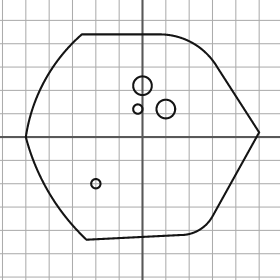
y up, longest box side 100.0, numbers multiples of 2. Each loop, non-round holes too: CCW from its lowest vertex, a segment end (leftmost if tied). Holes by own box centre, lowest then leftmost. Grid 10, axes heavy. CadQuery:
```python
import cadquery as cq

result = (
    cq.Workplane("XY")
    .moveTo(-24.0, -44.0)
    .lineTo(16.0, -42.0)
    .threePointArc((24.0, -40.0), (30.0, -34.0))
    .lineTo(50.0, 2.0)
    .lineTo(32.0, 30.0)
    .threePointArc((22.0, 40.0), (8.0, 44.0))
    .lineTo(-26.0, 44.0)
    .threePointArc((-42.0, 24.0), (-50.0, 0.0))
    .threePointArc((-40.0, -24.0), (-24.0, -44.0))
    .close()
    .moveTo(-20.0, -20.0)
    .circle(2.0)
    .moveTo(-2.0, 12.0)
    .circle(2.0)
    .moveTo(10.0, 12.0)
    .circle(4.0)
    .moveTo(0.0, 22.0)
    .circle(4.0)
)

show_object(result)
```